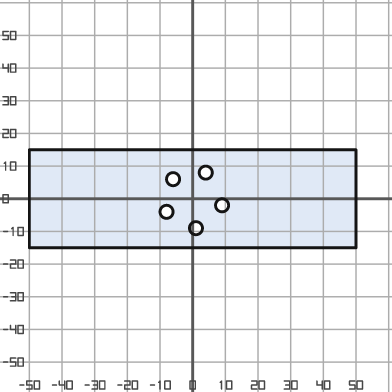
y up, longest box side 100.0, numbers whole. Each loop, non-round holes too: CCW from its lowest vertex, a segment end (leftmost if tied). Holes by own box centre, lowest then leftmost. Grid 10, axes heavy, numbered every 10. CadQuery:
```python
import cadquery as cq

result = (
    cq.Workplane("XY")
    .moveTo(-50.0, -15.0)
    .lineTo(50.0, -15.0)
    .lineTo(50.0, 15.0)
    .lineTo(-50.0, 15.0)
    .close()
    .moveTo(1.0, -9.0)
    .circle(2.0)
    .moveTo(-8.0, -4.0)
    .circle(2.0)
    .moveTo(9.0, -2.0)
    .circle(2.0)
    .moveTo(-6.0, 6.0)
    .circle(2.0)
    .moveTo(4.0, 8.0)
    .circle(2.0)
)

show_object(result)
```